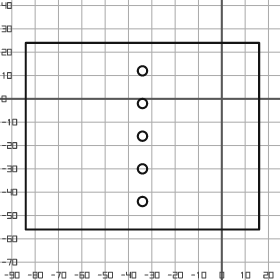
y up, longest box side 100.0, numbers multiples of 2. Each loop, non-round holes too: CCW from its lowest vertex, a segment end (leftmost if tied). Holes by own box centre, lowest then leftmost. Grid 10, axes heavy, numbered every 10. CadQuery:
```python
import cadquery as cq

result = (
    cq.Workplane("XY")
    .moveTo(-84.0, -56.0)
    .lineTo(16.0, -56.0)
    .lineTo(16.0, 24.0)
    .lineTo(-84.0, 24.0)
    .close()
    .moveTo(-34.0, -44.0)
    .circle(2.0)
    .moveTo(-34.0, -30.0)
    .circle(2.0)
    .moveTo(-34.0, -16.0)
    .circle(2.0)
    .moveTo(-34.0, -2.0)
    .circle(2.0)
    .moveTo(-34.0, 12.0)
    .circle(2.0)
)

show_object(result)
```